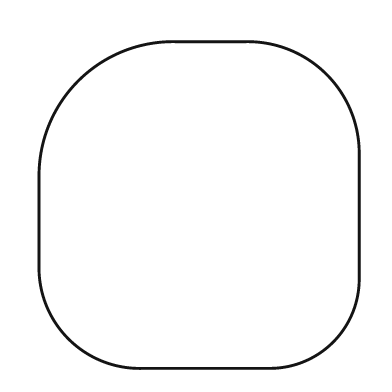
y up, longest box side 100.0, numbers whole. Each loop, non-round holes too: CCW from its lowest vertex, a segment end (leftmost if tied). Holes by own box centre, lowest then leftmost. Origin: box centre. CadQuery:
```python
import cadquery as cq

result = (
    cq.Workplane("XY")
    .moveTo(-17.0, -50.0)
    .lineTo(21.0, -50.0)
    .threePointArc((41.0, -42.0), (49.0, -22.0))
    .lineTo(49.0, 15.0)
    .threePointArc((39.0, 40.0), (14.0, 50.0))
    .lineTo(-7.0, 50.0)
    .threePointArc((-37.0, 38.0), (-49.0, 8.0))
    .lineTo(-49.0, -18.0)
    .threePointArc((-40.0, -41.0), (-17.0, -50.0))
    .close()
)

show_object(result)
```